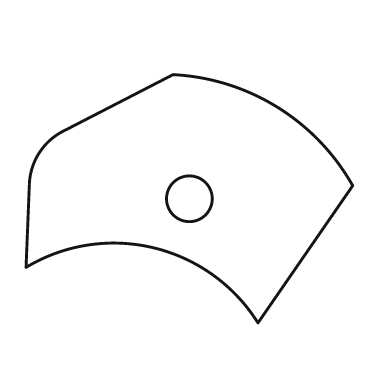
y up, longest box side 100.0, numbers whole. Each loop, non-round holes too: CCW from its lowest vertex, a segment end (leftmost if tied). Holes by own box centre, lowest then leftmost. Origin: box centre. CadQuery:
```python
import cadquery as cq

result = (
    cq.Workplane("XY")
    .moveTo(21.0, -38.0)
    .lineTo(50.0, 4.0)
    .threePointArc((27.0, 28.0), (-5.0, 38.0))
    .lineTo(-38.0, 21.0)
    .threePointArc((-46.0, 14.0), (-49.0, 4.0))
    .lineTo(-50.0, -21.0)
    .threePointArc((-11.0, -15.0), (21.0, -38.0))
    .close()
    .moveTo(0.0, 0.0)
    .circle(7.0)
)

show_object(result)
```